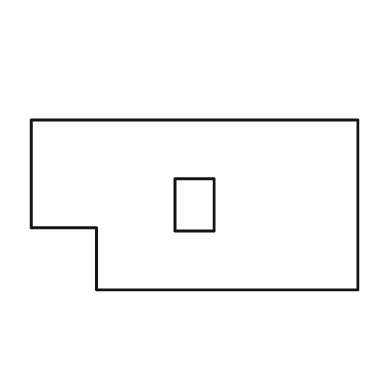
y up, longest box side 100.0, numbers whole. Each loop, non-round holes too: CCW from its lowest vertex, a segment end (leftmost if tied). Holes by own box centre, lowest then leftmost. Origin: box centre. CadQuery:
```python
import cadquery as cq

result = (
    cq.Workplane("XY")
    .moveTo(-30.0, -26.0)
    .lineTo(50.0, -26.0)
    .lineTo(50.0, 26.0)
    .lineTo(-50.0, 26.0)
    .lineTo(-50.0, -7.0)
    .lineTo(-30.0, -7.0)
    .close()
    .moveTo(-6.0, -8.0)
    .lineTo(6.0, -8.0)
    .lineTo(6.0, 8.0)
    .lineTo(-6.0, 8.0)
    .close()
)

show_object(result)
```